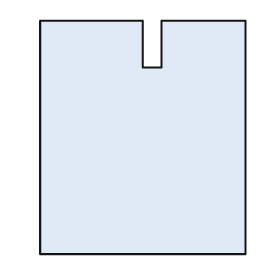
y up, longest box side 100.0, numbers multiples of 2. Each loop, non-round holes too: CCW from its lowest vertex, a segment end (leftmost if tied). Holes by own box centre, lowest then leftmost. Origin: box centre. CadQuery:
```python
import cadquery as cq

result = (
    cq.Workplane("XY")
    .moveTo(-44.0, -50.0)
    .lineTo(44.0, -50.0)
    .lineTo(44.0, 50.0)
    .lineTo(8.0, 50.0)
    .lineTo(8.0, 30.0)
    .lineTo(0.0, 30.0)
    .lineTo(0.0, 50.0)
    .lineTo(-44.0, 50.0)
    .close()
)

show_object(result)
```